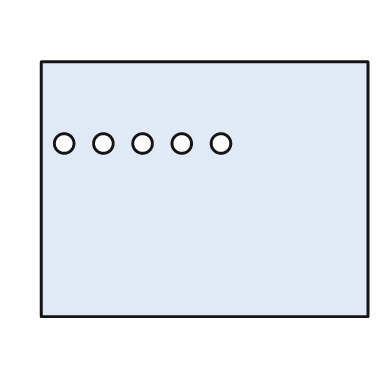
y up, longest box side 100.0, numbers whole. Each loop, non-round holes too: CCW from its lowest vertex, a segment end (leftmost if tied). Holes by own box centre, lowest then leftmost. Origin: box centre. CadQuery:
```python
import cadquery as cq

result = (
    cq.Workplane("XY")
    .moveTo(-50.0, -39.0)
    .lineTo(50.0, -39.0)
    .lineTo(50.0, 39.0)
    .lineTo(-50.0, 39.0)
    .close()
    .moveTo(-43.0, 14.0)
    .circle(3.0)
    .moveTo(-31.0, 14.0)
    .circle(3.0)
    .moveTo(-19.0, 14.0)
    .circle(3.0)
    .moveTo(-7.0, 14.0)
    .circle(3.0)
    .moveTo(5.0, 14.0)
    .circle(3.0)
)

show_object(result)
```